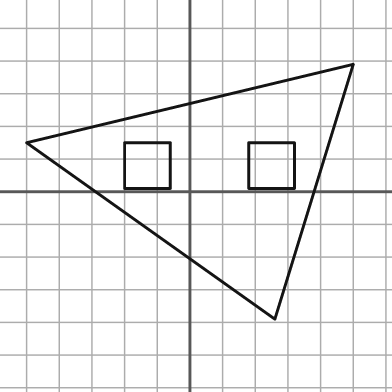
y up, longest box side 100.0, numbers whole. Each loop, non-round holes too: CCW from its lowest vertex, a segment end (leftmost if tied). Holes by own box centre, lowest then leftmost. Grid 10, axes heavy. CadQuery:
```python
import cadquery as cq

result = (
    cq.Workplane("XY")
    .moveTo(26.0, -39.0)
    .lineTo(50.0, 39.0)
    .lineTo(-50.0, 15.0)
    .close()
    .moveTo(-20.0, 1.0)
    .lineTo(-6.0, 1.0)
    .lineTo(-6.0, 15.0)
    .lineTo(-20.0, 15.0)
    .close()
    .moveTo(18.0, 1.0)
    .lineTo(32.0, 1.0)
    .lineTo(32.0, 15.0)
    .lineTo(18.0, 15.0)
    .close()
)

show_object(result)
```